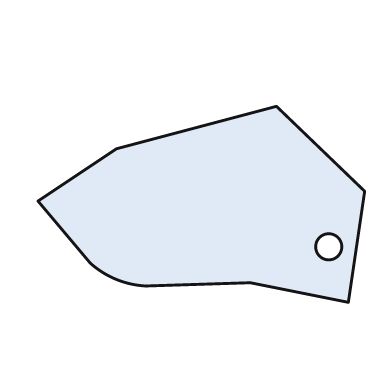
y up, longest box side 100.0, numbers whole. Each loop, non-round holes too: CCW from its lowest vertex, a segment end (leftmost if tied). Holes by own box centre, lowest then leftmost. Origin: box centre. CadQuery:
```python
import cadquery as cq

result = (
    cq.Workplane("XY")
    .moveTo(45.0, -30.0)
    .lineTo(50.0, 4.0)
    .lineTo(23.0, 30.0)
    .lineTo(-26.0, 17.0)
    .lineTo(-50.0, 1.0)
    .lineTo(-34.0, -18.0)
    .threePointArc((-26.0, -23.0), (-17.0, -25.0))
    .lineTo(15.0, -24.0)
    .close()
    .moveTo(39.0, -13.0)
    .circle(4.0)
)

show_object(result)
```